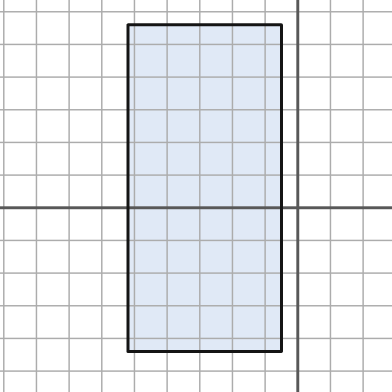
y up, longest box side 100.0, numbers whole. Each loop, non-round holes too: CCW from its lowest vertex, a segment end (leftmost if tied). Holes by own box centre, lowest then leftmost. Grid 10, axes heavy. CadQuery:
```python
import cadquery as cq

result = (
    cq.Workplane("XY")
    .moveTo(-52.0, -44.0)
    .lineTo(-5.0, -44.0)
    .lineTo(-5.0, 56.0)
    .lineTo(-52.0, 56.0)
    .close()
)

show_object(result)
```